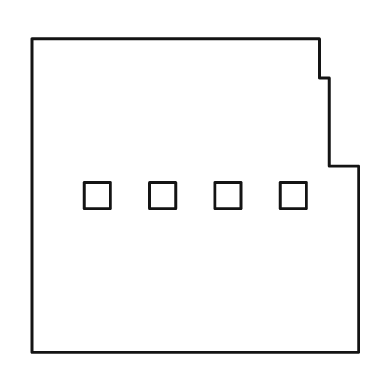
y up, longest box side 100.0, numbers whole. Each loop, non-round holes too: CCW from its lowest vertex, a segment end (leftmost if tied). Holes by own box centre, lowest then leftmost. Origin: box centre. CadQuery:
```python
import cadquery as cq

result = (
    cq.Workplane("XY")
    .moveTo(-50.0, -48.0)
    .lineTo(50.0, -48.0)
    .lineTo(50.0, 9.0)
    .lineTo(41.0, 9.0)
    .lineTo(41.0, 36.0)
    .lineTo(38.0, 36.0)
    .lineTo(38.0, 48.0)
    .lineTo(-50.0, 48.0)
    .close()
    .moveTo(-34.0, -4.0)
    .lineTo(-26.0, -4.0)
    .lineTo(-26.0, 4.0)
    .lineTo(-34.0, 4.0)
    .close()
    .moveTo(-14.0, -4.0)
    .lineTo(-6.0, -4.0)
    .lineTo(-6.0, 4.0)
    .lineTo(-14.0, 4.0)
    .close()
    .moveTo(6.0, -4.0)
    .lineTo(14.0, -4.0)
    .lineTo(14.0, 4.0)
    .lineTo(6.0, 4.0)
    .close()
    .moveTo(26.0, -4.0)
    .lineTo(34.0, -4.0)
    .lineTo(34.0, 4.0)
    .lineTo(26.0, 4.0)
    .close()
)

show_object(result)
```